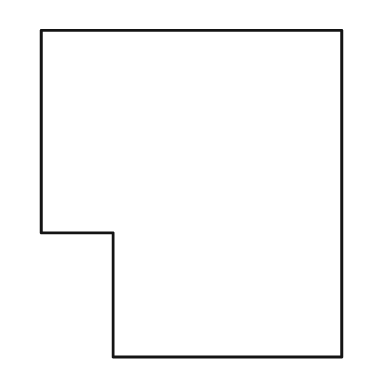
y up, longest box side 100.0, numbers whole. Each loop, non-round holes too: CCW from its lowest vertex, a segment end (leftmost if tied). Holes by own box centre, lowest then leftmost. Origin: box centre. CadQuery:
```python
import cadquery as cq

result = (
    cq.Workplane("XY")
    .moveTo(-24.0, -50.0)
    .lineTo(46.0, -50.0)
    .lineTo(46.0, 50.0)
    .lineTo(-46.0, 50.0)
    .lineTo(-46.0, -12.0)
    .lineTo(-24.0, -12.0)
    .close()
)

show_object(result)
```